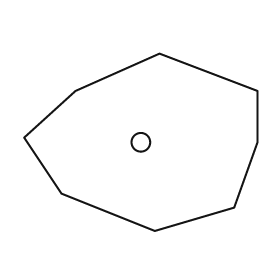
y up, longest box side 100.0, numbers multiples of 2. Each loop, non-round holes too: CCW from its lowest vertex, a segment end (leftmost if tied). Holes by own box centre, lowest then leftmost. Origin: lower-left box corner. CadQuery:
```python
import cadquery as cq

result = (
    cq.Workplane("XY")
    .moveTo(56.0, 0.0)
    .lineTo(90.0, 10.0)
    .lineTo(100.0, 38.0)
    .lineTo(100.0, 60.0)
    .lineTo(58.0, 76.0)
    .lineTo(22.0, 60.0)
    .lineTo(0.0, 40.0)
    .lineTo(16.0, 16.0)
    .close()
    .moveTo(50.0, 38.0)
    .circle(4.0)
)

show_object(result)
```